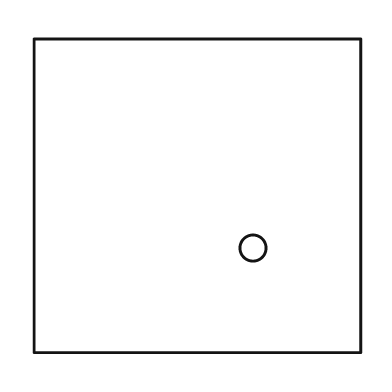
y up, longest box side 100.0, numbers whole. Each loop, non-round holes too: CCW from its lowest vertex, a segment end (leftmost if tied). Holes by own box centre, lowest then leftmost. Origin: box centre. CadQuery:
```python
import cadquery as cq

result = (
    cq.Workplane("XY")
    .moveTo(-50.0, -48.0)
    .lineTo(50.0, -48.0)
    .lineTo(50.0, 48.0)
    .lineTo(-50.0, 48.0)
    .close()
    .moveTo(17.0, -16.0)
    .circle(4.0)
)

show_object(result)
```